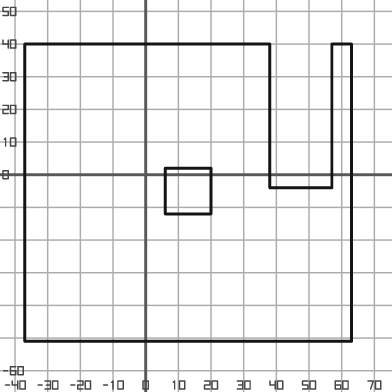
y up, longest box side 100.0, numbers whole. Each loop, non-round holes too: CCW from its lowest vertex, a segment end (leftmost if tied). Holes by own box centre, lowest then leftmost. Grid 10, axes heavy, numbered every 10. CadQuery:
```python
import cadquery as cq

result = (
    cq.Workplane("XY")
    .moveTo(-37.0, -51.0)
    .lineTo(63.0, -51.0)
    .lineTo(63.0, 40.0)
    .lineTo(57.0, 40.0)
    .lineTo(57.0, -4.0)
    .lineTo(38.0, -4.0)
    .lineTo(38.0, 40.0)
    .lineTo(-37.0, 40.0)
    .close()
    .moveTo(6.0, -12.0)
    .lineTo(20.0, -12.0)
    .lineTo(20.0, 2.0)
    .lineTo(6.0, 2.0)
    .close()
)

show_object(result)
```